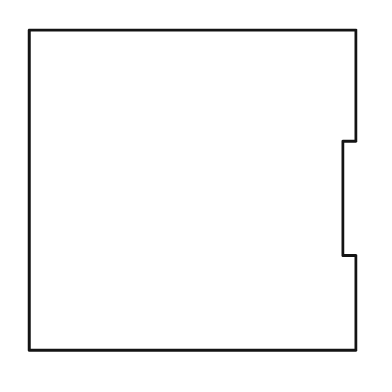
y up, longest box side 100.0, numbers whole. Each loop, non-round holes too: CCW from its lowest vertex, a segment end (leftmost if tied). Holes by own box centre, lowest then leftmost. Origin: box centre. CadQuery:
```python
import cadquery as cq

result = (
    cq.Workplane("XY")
    .moveTo(-50.0, -49.0)
    .lineTo(50.0, -49.0)
    .lineTo(50.0, -20.0)
    .lineTo(46.0, -20.0)
    .lineTo(46.0, 15.0)
    .lineTo(50.0, 15.0)
    .lineTo(50.0, 49.0)
    .lineTo(-50.0, 49.0)
    .close()
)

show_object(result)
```